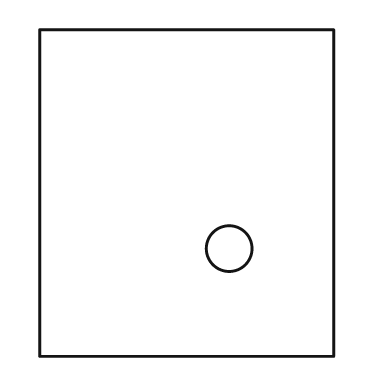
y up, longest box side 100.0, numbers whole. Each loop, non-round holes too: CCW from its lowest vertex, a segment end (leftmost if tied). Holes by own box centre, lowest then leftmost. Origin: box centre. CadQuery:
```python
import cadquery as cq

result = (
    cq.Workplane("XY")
    .moveTo(-45.0, -50.0)
    .lineTo(45.0, -50.0)
    .lineTo(45.0, 50.0)
    .lineTo(-45.0, 50.0)
    .close()
    .moveTo(13.0, -17.0)
    .circle(7.0)
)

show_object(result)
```